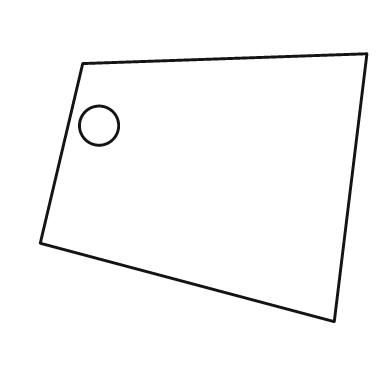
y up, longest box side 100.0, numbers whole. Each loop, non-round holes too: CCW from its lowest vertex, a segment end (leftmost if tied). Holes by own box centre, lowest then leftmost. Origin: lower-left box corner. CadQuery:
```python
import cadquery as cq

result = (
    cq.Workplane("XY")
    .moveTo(90.0, 0.0)
    .lineTo(100.0, 82.0)
    .lineTo(13.0, 79.0)
    .lineTo(0.0, 24.0)
    .close()
    .moveTo(18.0, 60.0)
    .circle(6.0)
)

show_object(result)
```